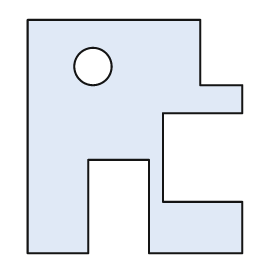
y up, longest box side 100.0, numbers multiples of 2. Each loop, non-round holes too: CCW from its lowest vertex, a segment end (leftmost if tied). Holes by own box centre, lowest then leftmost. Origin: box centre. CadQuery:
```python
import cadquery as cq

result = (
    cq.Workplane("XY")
    .moveTo(-46.0, -50.0)
    .lineTo(-20.0, -50.0)
    .lineTo(-20.0, -10.0)
    .lineTo(6.0, -10.0)
    .lineTo(6.0, -50.0)
    .lineTo(46.0, -50.0)
    .lineTo(46.0, -28.0)
    .lineTo(12.0, -28.0)
    .lineTo(12.0, 10.0)
    .lineTo(46.0, 10.0)
    .lineTo(46.0, 22.0)
    .lineTo(28.0, 22.0)
    .lineTo(28.0, 50.0)
    .lineTo(-46.0, 50.0)
    .close()
    .moveTo(-18.0, 30.0)
    .circle(8.0)
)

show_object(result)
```